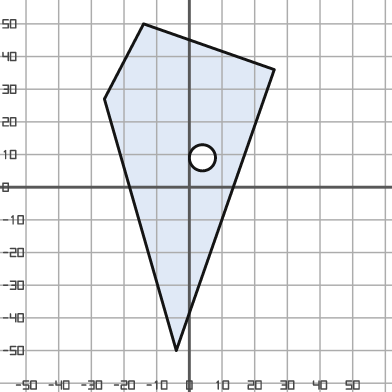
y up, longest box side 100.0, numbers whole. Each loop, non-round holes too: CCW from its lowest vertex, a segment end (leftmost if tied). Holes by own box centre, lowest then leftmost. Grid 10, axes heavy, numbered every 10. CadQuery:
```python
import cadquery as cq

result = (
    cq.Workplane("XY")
    .moveTo(-4.0, -50.0)
    .lineTo(26.0, 36.0)
    .lineTo(-14.0, 50.0)
    .lineTo(-26.0, 27.0)
    .close()
    .moveTo(4.0, 9.0)
    .circle(4.0)
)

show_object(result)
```